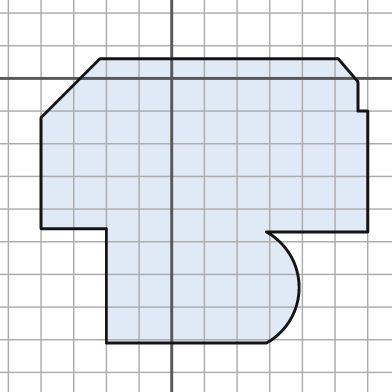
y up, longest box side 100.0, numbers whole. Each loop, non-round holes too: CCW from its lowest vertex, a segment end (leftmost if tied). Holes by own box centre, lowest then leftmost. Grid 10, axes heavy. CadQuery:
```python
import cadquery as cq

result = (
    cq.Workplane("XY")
    .moveTo(-20.0, -81.0)
    .lineTo(29.0, -81.0)
    .threePointArc((39.0, -64.0), (29.0, -47.0))
    .lineTo(60.0, -47.0)
    .lineTo(60.0, -10.0)
    .lineTo(57.0, -10.0)
    .lineTo(57.0, -1.0)
    .lineTo(51.0, 6.0)
    .lineTo(-22.0, 6.0)
    .lineTo(-40.0, -12.0)
    .lineTo(-40.0, -46.0)
    .lineTo(-20.0, -46.0)
    .close()
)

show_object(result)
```